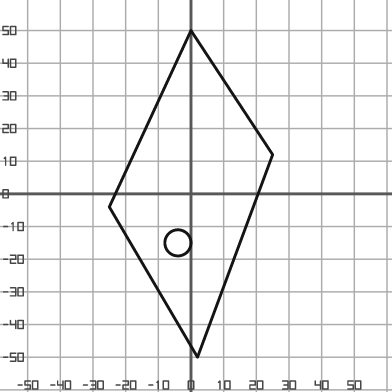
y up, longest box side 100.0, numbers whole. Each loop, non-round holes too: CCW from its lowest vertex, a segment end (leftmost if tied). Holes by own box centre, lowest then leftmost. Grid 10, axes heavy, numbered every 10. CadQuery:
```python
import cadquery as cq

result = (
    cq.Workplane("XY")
    .moveTo(2.0, -50.0)
    .lineTo(25.0, 12.0)
    .lineTo(0.0, 50.0)
    .lineTo(-25.0, -4.0)
    .close()
    .moveTo(-4.0, -15.0)
    .circle(4.0)
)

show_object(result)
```